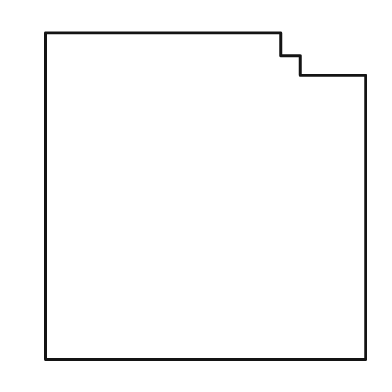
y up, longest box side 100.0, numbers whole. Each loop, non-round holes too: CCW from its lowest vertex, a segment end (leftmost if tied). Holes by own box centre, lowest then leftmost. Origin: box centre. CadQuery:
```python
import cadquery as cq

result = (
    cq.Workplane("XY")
    .moveTo(-49.0, -50.0)
    .lineTo(49.0, -50.0)
    .lineTo(49.0, 37.0)
    .lineTo(29.0, 37.0)
    .lineTo(29.0, 43.0)
    .lineTo(23.0, 43.0)
    .lineTo(23.0, 50.0)
    .lineTo(-49.0, 50.0)
    .close()
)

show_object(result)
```